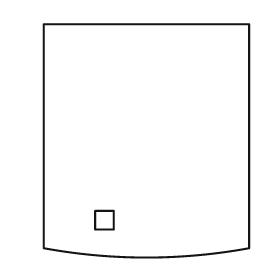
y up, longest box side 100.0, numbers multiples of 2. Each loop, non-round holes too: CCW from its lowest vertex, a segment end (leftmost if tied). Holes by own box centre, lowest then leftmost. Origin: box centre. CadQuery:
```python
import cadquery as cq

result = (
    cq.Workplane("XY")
    .moveTo(-44.0, -46.0)
    .threePointArc((0.0, -50.0), (44.0, -46.0))
    .lineTo(44.0, 50.0)
    .lineTo(-44.0, 50.0)
    .close()
    .moveTo(-22.0, -38.0)
    .lineTo(-14.0, -38.0)
    .lineTo(-14.0, -30.0)
    .lineTo(-22.0, -30.0)
    .close()
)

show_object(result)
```